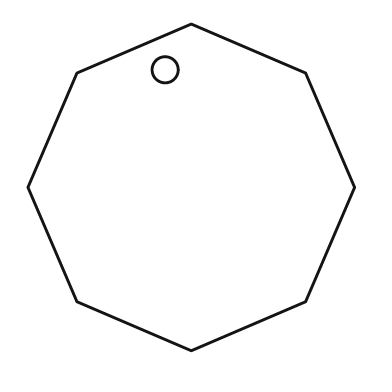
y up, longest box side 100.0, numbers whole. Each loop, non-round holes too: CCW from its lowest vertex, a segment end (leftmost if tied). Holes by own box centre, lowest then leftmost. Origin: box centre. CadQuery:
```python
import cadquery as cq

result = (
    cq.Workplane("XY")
    .moveTo(0.0, -50.0)
    .lineTo(35.0, -35.0)
    .lineTo(50.0, 0.0)
    .lineTo(35.0, 35.0)
    .lineTo(0.0, 50.0)
    .lineTo(-35.0, 35.0)
    .lineTo(-50.0, 0.0)
    .lineTo(-35.0, -35.0)
    .close()
    .moveTo(-8.0, 36.0)
    .circle(4.0)
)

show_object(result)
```